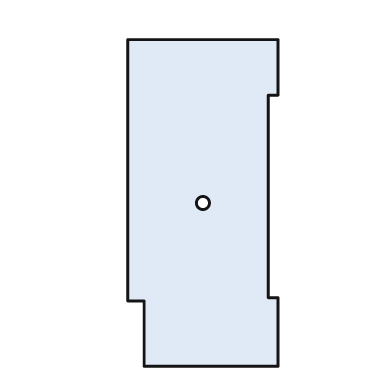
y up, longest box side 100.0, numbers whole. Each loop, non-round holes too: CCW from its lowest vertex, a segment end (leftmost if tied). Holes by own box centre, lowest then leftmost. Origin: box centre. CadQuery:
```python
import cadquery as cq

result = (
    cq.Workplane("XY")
    .moveTo(-18.0, -50.0)
    .lineTo(23.0, -50.0)
    .lineTo(23.0, -29.0)
    .lineTo(20.0, -29.0)
    .lineTo(20.0, 33.0)
    .lineTo(23.0, 33.0)
    .lineTo(23.0, 50.0)
    .lineTo(-23.0, 50.0)
    .lineTo(-23.0, -30.0)
    .lineTo(-18.0, -30.0)
    .close()
    .moveTo(0.0, 0.0)
    .circle(2.0)
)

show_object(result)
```